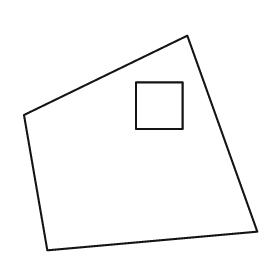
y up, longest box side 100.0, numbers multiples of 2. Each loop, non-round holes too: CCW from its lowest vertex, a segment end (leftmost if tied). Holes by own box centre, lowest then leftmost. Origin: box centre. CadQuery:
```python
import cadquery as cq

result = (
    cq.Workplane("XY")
    .moveTo(-40.0, -46.0)
    .lineTo(50.0, -38.0)
    .lineTo(20.0, 46.0)
    .lineTo(-50.0, 12.0)
    .close()
    .moveTo(-2.0, 6.0)
    .lineTo(18.0, 6.0)
    .lineTo(18.0, 26.0)
    .lineTo(-2.0, 26.0)
    .close()
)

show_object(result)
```